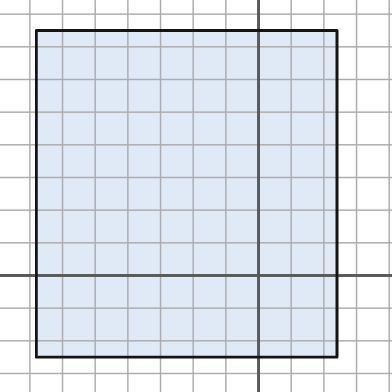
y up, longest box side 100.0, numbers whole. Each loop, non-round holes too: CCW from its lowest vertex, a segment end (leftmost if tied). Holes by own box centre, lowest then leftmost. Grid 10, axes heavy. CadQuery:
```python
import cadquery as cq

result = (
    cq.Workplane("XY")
    .moveTo(-68.0, -25.0)
    .lineTo(24.0, -25.0)
    .lineTo(24.0, 75.0)
    .lineTo(-68.0, 75.0)
    .close()
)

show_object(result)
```